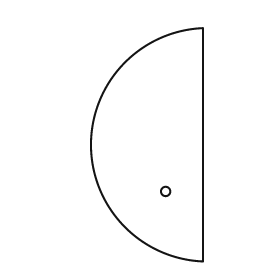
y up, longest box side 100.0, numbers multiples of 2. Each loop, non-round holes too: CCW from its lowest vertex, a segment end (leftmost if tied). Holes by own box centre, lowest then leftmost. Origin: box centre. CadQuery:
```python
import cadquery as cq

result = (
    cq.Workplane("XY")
    .moveTo(24.0, -50.0)
    .lineTo(24.0, 50.0)
    .threePointArc((-24.0, 0.0), (24.0, -50.0))
    .close()
    .moveTo(8.0, -20.0)
    .circle(2.0)
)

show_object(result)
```